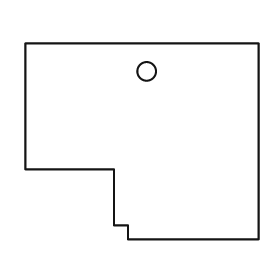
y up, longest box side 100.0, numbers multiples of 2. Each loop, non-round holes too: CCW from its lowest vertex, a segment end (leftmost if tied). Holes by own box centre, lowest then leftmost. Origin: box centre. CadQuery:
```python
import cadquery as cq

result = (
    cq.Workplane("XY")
    .moveTo(-6.0, -42.0)
    .lineTo(50.0, -42.0)
    .lineTo(50.0, 42.0)
    .lineTo(-50.0, 42.0)
    .lineTo(-50.0, -12.0)
    .lineTo(-12.0, -12.0)
    .lineTo(-12.0, -36.0)
    .lineTo(-6.0, -36.0)
    .close()
    .moveTo(2.0, 30.0)
    .circle(4.0)
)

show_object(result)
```